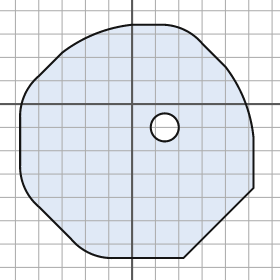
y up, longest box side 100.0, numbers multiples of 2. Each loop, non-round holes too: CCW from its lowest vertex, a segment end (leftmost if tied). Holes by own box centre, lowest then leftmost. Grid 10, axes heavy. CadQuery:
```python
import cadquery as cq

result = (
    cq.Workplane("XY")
    .moveTo(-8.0, -66.0)
    .lineTo(22.0, -66.0)
    .lineTo(52.0, -36.0)
    .lineTo(52.0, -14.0)
    .threePointArc((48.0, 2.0), (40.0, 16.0))
    .lineTo(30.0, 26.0)
    .threePointArc((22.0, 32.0), (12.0, 34.0))
    .lineTo(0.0, 34.0)
    .threePointArc((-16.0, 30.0), (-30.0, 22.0))
    .lineTo(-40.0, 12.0)
    .threePointArc((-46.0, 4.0), (-48.0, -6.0))
    .lineTo(-48.0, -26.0)
    .threePointArc((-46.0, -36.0), (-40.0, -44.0))
    .lineTo(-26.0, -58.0)
    .threePointArc((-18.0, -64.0), (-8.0, -66.0))
    .close()
    .moveTo(14.0, -10.0)
    .circle(6.0)
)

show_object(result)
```